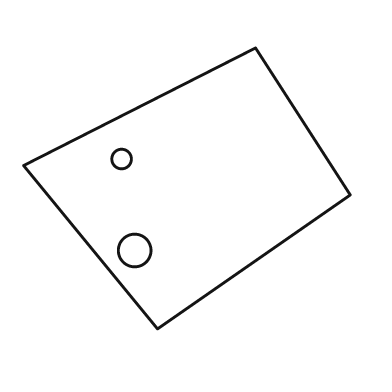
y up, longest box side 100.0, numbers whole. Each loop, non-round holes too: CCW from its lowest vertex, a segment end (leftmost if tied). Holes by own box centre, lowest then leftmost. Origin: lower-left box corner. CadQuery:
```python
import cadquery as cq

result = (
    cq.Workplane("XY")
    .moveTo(41.0, 0.0)
    .lineTo(100.0, 41.0)
    .lineTo(71.0, 86.0)
    .lineTo(0.0, 50.0)
    .close()
    .moveTo(34.0, 24.0)
    .circle(5.0)
    .moveTo(30.0, 52.0)
    .circle(3.0)
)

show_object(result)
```